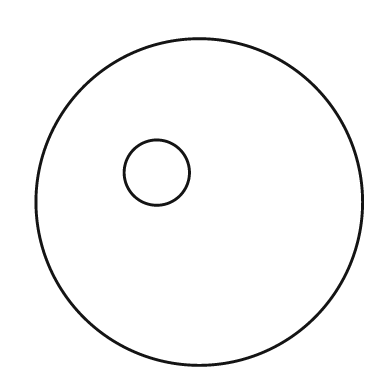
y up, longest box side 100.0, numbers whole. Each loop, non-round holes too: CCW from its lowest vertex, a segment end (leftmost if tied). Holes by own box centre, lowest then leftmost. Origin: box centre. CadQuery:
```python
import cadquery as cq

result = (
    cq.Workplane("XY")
    .moveTo(0.0, 0.0)
    .circle(50.0)
    .moveTo(-13.0, 9.0)
    .circle(10.0)
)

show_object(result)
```